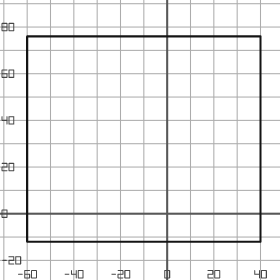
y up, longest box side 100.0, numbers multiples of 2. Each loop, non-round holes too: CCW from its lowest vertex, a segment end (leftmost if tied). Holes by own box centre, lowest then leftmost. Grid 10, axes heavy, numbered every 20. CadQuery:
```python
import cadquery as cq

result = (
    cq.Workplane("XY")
    .moveTo(-60.0, -12.0)
    .lineTo(40.0, -12.0)
    .lineTo(40.0, 76.0)
    .lineTo(-60.0, 76.0)
    .close()
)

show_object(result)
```